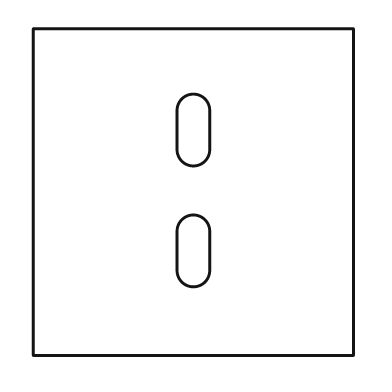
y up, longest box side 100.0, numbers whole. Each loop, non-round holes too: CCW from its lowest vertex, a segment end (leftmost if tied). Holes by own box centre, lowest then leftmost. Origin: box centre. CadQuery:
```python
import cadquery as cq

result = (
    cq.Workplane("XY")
    .moveTo(-49.0, -50.0)
    .lineTo(49.0, -50.0)
    .lineTo(49.0, 50.0)
    .lineTo(-49.0, 50.0)
    .close()
    .moveTo(-5.0, -24.0)
    .threePointArc((0.0, -29.0), (5.0, -24.0))
    .lineTo(5.0, -12.0)
    .threePointArc((0.0, -7.0), (-5.0, -12.0))
    .close()
    .moveTo(-5.0, 13.0)
    .threePointArc((0.0, 8.0), (5.0, 13.0))
    .lineTo(5.0, 25.0)
    .threePointArc((0.0, 30.0), (-5.0, 25.0))
    .close()
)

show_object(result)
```